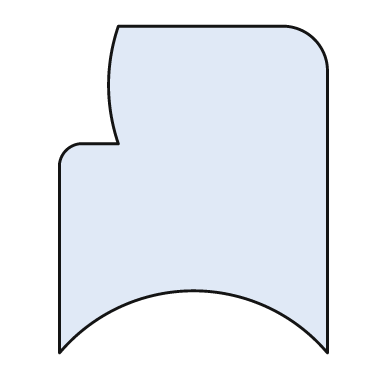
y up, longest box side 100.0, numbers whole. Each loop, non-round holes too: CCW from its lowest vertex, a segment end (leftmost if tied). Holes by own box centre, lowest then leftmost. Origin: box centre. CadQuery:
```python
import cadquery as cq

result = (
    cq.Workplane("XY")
    .moveTo(-41.0, -50.0)
    .threePointArc((0.0, -31.0), (41.0, -50.0))
    .lineTo(41.0, 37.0)
    .threePointArc((37.0, 46.0), (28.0, 50.0))
    .lineTo(-23.0, 50.0)
    .threePointArc((-26.0, 32.0), (-23.0, 14.0))
    .lineTo(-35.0, 14.0)
    .threePointArc((-39.0, 12.0), (-41.0, 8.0))
    .close()
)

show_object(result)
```